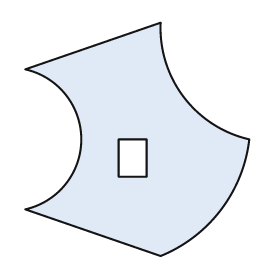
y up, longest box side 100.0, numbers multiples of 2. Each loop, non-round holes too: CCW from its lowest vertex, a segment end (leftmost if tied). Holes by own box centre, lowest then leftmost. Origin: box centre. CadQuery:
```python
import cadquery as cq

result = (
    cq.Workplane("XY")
    .moveTo(10.0, -50.0)
    .threePointArc((36.0, -30.0), (48.0, 0.0))
    .threePointArc((20.0, 18.0), (10.0, 50.0))
    .lineTo(-48.0, 30.0)
    .threePointArc((-24.0, 0.0), (-48.0, -30.0))
    .close()
    .moveTo(-8.0, -16.0)
    .lineTo(4.0, -16.0)
    .lineTo(4.0, 0.0)
    .lineTo(-8.0, 0.0)
    .close()
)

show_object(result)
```